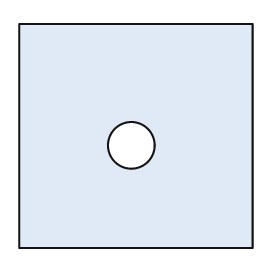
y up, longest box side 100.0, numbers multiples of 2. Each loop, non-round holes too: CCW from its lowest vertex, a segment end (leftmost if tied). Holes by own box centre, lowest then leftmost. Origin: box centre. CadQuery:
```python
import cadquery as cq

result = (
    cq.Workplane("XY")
    .moveTo(-50.0, -48.0)
    .lineTo(50.0, -48.0)
    .lineTo(50.0, 48.0)
    .lineTo(-50.0, 48.0)
    .close()
    .moveTo(-2.0, -4.0)
    .circle(10.0)
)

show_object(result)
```